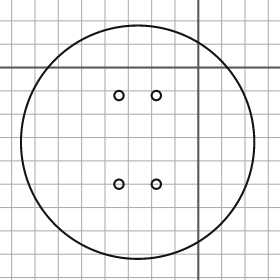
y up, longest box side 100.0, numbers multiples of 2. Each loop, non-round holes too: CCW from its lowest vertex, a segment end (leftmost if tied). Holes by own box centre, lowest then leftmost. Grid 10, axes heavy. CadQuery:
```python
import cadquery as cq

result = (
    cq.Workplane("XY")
    .moveTo(-26.0, -32.0)
    .circle(50.0)
    .moveTo(-34.0, -50.0)
    .circle(2.0)
    .moveTo(-18.0, -50.0)
    .circle(2.0)
    .moveTo(-34.0, -12.0)
    .circle(2.0)
    .moveTo(-18.0, -12.0)
    .circle(2.0)
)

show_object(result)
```